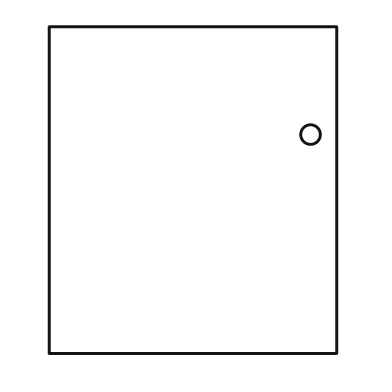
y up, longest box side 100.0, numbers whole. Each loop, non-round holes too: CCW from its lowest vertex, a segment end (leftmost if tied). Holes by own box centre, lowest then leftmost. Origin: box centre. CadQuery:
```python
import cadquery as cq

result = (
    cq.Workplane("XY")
    .moveTo(-44.0, -50.0)
    .lineTo(44.0, -50.0)
    .lineTo(44.0, 50.0)
    .lineTo(-44.0, 50.0)
    .close()
    .moveTo(36.0, 17.0)
    .circle(3.0)
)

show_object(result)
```